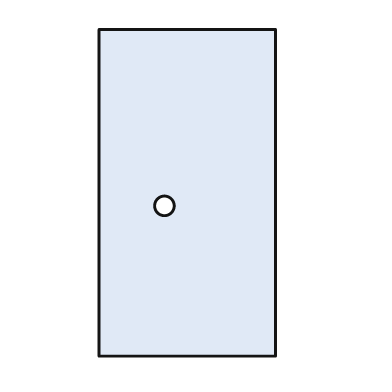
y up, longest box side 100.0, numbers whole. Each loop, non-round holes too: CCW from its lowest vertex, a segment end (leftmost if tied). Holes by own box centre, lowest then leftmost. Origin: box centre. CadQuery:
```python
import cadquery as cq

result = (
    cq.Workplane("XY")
    .moveTo(-27.0, -50.0)
    .lineTo(27.0, -50.0)
    .lineTo(27.0, 50.0)
    .lineTo(-27.0, 50.0)
    .close()
    .moveTo(-7.0, -4.0)
    .circle(3.0)
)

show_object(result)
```